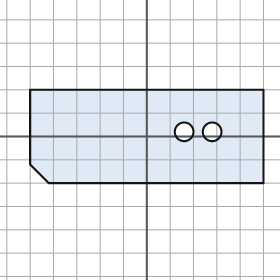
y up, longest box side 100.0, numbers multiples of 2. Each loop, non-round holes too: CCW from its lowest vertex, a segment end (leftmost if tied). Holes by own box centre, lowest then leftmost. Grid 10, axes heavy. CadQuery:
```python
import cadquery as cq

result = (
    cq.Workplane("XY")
    .moveTo(-42.0, -20.0)
    .lineTo(50.0, -20.0)
    .lineTo(50.0, 20.0)
    .lineTo(-50.0, 20.0)
    .lineTo(-50.0, -12.0)
    .close()
    .moveTo(16.0, 2.0)
    .circle(4.0)
    .moveTo(28.0, 2.0)
    .circle(4.0)
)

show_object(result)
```